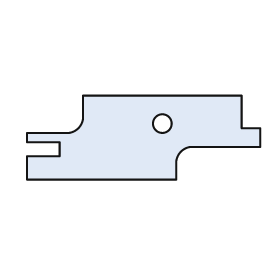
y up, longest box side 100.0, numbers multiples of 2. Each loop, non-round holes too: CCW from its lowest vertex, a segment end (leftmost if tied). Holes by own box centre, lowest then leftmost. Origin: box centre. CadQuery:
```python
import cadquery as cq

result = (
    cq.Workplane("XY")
    .moveTo(-50.0, -18.0)
    .lineTo(14.0, -18.0)
    .lineTo(14.0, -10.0)
    .threePointArc((16.0, -6.0), (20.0, -4.0))
    .lineTo(50.0, -4.0)
    .lineTo(50.0, 4.0)
    .lineTo(42.0, 4.0)
    .lineTo(42.0, 18.0)
    .lineTo(-26.0, 18.0)
    .lineTo(-26.0, 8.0)
    .threePointArc((-28.0, 4.0), (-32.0, 2.0))
    .lineTo(-50.0, 2.0)
    .lineTo(-50.0, -2.0)
    .lineTo(-36.0, -2.0)
    .lineTo(-36.0, -8.0)
    .lineTo(-50.0, -8.0)
    .close()
    .moveTo(8.0, 6.0)
    .circle(4.0)
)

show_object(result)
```